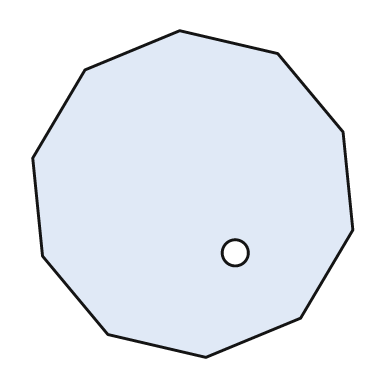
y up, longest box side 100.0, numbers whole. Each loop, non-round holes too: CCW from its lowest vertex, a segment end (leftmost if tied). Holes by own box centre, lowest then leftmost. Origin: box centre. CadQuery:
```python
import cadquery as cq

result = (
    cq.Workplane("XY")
    .moveTo(4.0, -50.0)
    .lineTo(33.0, -38.0)
    .lineTo(49.0, -11.0)
    .lineTo(46.0, 19.0)
    .lineTo(26.0, 43.0)
    .lineTo(-4.0, 50.0)
    .lineTo(-33.0, 38.0)
    .lineTo(-49.0, 11.0)
    .lineTo(-46.0, -19.0)
    .lineTo(-26.0, -43.0)
    .close()
    .moveTo(13.0, -18.0)
    .circle(4.0)
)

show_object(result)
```